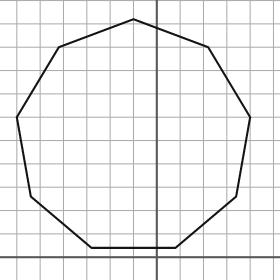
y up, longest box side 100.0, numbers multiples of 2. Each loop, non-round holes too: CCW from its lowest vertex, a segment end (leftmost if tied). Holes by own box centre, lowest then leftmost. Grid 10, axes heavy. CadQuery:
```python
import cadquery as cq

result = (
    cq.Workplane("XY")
    .moveTo(-28.0, 4.0)
    .lineTo(8.0, 4.0)
    .lineTo(34.0, 26.0)
    .lineTo(40.0, 60.0)
    .lineTo(22.0, 90.0)
    .lineTo(-10.0, 102.0)
    .lineTo(-42.0, 90.0)
    .lineTo(-60.0, 60.0)
    .lineTo(-54.0, 26.0)
    .close()
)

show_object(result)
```